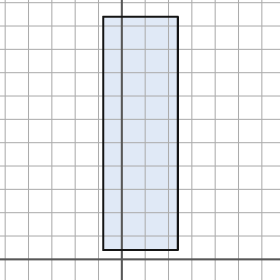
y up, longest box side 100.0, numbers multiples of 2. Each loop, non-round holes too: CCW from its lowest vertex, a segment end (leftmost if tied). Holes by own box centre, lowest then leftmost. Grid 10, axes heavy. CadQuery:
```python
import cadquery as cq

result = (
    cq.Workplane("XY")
    .moveTo(-8.0, 4.0)
    .lineTo(24.0, 4.0)
    .lineTo(24.0, 104.0)
    .lineTo(-8.0, 104.0)
    .close()
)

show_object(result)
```